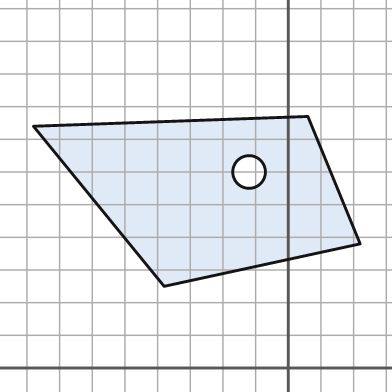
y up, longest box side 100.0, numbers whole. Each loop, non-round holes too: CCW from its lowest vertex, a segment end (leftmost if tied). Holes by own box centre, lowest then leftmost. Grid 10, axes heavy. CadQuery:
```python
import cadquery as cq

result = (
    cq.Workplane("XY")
    .moveTo(-38.0, 25.0)
    .lineTo(22.0, 38.0)
    .lineTo(6.0, 77.0)
    .lineTo(-78.0, 74.0)
    .close()
    .moveTo(-12.0, 60.0)
    .circle(5.0)
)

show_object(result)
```